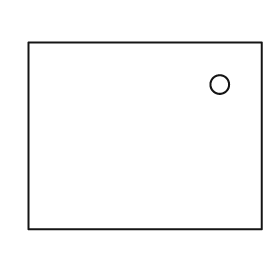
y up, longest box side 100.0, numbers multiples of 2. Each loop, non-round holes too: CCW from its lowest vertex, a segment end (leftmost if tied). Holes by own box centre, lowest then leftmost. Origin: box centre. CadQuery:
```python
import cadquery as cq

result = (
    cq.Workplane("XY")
    .moveTo(-50.0, -40.0)
    .lineTo(50.0, -40.0)
    .lineTo(50.0, 40.0)
    .lineTo(-50.0, 40.0)
    .close()
    .moveTo(32.0, 22.0)
    .circle(4.0)
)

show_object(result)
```